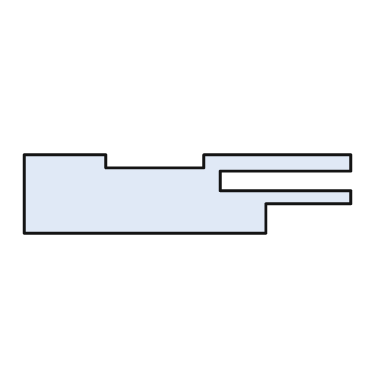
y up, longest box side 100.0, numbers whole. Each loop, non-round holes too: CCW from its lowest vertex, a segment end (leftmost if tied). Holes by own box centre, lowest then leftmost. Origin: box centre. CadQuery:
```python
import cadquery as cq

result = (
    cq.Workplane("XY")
    .moveTo(-50.0, -12.0)
    .lineTo(24.0, -12.0)
    .lineTo(24.0, -3.0)
    .lineTo(50.0, -3.0)
    .lineTo(50.0, 1.0)
    .lineTo(10.0, 1.0)
    .lineTo(10.0, 7.0)
    .lineTo(50.0, 7.0)
    .lineTo(50.0, 12.0)
    .lineTo(5.0, 12.0)
    .lineTo(5.0, 8.0)
    .lineTo(-25.0, 8.0)
    .lineTo(-25.0, 12.0)
    .lineTo(-50.0, 12.0)
    .close()
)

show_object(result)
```